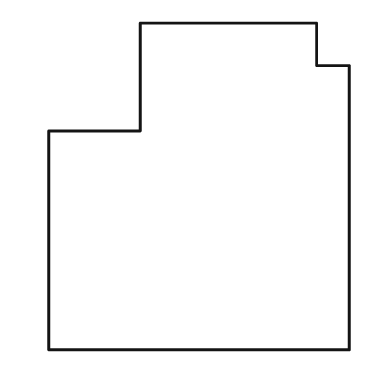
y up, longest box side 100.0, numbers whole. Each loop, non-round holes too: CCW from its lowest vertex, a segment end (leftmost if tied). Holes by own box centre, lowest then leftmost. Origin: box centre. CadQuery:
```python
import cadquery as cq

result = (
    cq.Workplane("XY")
    .moveTo(-46.0, -50.0)
    .lineTo(46.0, -50.0)
    .lineTo(46.0, 37.0)
    .lineTo(36.0, 37.0)
    .lineTo(36.0, 50.0)
    .lineTo(-18.0, 50.0)
    .lineTo(-18.0, 17.0)
    .lineTo(-46.0, 17.0)
    .close()
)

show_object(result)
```